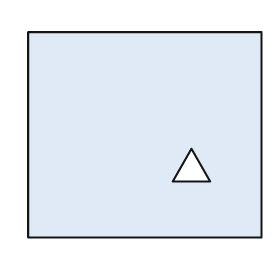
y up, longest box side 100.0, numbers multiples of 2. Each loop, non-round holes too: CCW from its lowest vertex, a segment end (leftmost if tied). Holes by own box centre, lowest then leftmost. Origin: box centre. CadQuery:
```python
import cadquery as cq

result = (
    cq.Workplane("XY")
    .moveTo(-50.0, -44.0)
    .lineTo(50.0, -44.0)
    .lineTo(50.0, 44.0)
    .lineTo(-50.0, 44.0)
    .close()
    .moveTo(12.0, -20.0)
    .lineTo(28.0, -20.0)
    .lineTo(20.0, -6.0)
    .close()
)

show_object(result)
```